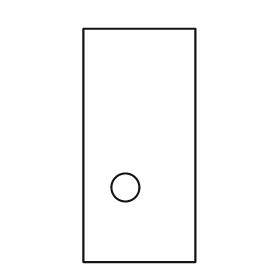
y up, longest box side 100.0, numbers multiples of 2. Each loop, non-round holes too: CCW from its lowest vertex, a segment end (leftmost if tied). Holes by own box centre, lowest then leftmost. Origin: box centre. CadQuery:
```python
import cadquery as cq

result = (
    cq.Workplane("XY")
    .moveTo(-24.0, -50.0)
    .lineTo(24.0, -50.0)
    .lineTo(24.0, 50.0)
    .lineTo(-24.0, 50.0)
    .close()
    .moveTo(-6.0, -18.0)
    .circle(6.0)
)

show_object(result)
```